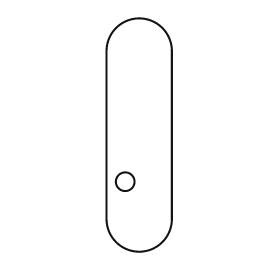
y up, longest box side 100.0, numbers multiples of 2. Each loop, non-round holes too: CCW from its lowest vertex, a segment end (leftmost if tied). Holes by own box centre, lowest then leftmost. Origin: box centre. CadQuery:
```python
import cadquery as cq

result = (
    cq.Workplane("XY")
    .moveTo(-14.0, -36.0)
    .threePointArc((0.0, -50.0), (14.0, -36.0))
    .lineTo(14.0, 36.0)
    .threePointArc((0.0, 50.0), (-14.0, 36.0))
    .close()
    .moveTo(-6.0, -20.0)
    .circle(4.0)
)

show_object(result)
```